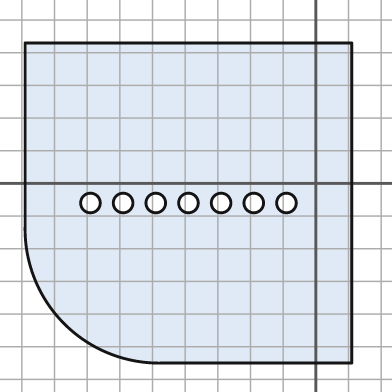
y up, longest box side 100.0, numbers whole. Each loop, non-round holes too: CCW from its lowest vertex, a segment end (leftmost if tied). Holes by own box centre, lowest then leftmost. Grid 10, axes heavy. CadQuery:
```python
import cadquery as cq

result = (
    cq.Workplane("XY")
    .moveTo(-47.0, -55.0)
    .lineTo(11.0, -55.0)
    .lineTo(11.0, 43.0)
    .lineTo(-89.0, 43.0)
    .lineTo(-89.0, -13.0)
    .threePointArc((-77.0, -43.0), (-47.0, -55.0))
    .close()
    .moveTo(-69.0, -6.0)
    .circle(3.0)
    .moveTo(-59.0, -6.0)
    .circle(3.0)
    .moveTo(-49.0, -6.0)
    .circle(3.0)
    .moveTo(-39.0, -6.0)
    .circle(3.0)
    .moveTo(-29.0, -6.0)
    .circle(3.0)
    .moveTo(-19.0, -6.0)
    .circle(3.0)
    .moveTo(-9.0, -6.0)
    .circle(3.0)
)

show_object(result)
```